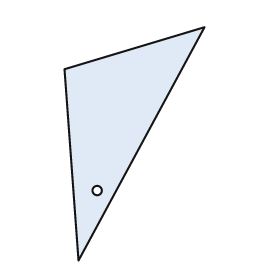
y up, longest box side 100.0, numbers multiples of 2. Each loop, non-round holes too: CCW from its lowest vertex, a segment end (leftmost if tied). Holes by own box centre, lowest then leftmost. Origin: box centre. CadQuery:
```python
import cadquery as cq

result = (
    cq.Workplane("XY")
    .moveTo(-24.0, -50.0)
    .lineTo(30.0, 50.0)
    .lineTo(-30.0, 32.0)
    .close()
    .moveTo(-16.0, -20.0)
    .circle(2.0)
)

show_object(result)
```